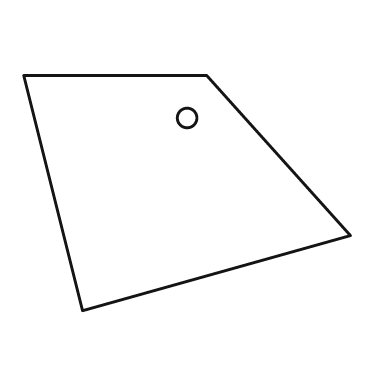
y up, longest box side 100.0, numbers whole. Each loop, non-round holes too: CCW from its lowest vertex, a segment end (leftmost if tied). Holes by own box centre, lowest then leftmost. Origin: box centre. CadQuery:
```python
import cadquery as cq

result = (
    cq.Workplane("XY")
    .moveTo(-32.0, -36.0)
    .lineTo(50.0, -13.0)
    .lineTo(6.0, 36.0)
    .lineTo(-50.0, 36.0)
    .close()
    .moveTo(0.0, 23.0)
    .circle(3.0)
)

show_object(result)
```